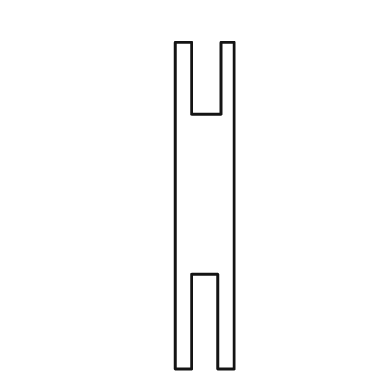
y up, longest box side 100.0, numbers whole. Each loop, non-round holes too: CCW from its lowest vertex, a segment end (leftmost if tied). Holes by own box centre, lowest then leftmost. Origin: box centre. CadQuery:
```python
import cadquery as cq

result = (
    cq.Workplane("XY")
    .moveTo(-9.0, -50.0)
    .lineTo(-4.0, -50.0)
    .lineTo(-4.0, -21.0)
    .lineTo(4.0, -21.0)
    .lineTo(4.0, -50.0)
    .lineTo(9.0, -50.0)
    .lineTo(9.0, 50.0)
    .lineTo(5.0, 50.0)
    .lineTo(5.0, 28.0)
    .lineTo(-4.0, 28.0)
    .lineTo(-4.0, 50.0)
    .lineTo(-9.0, 50.0)
    .close()
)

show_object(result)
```